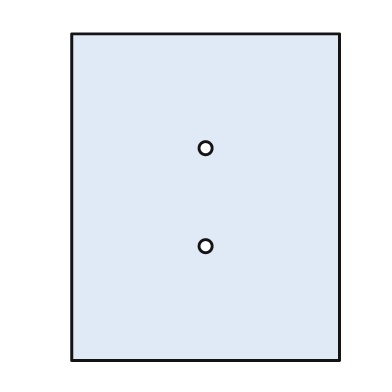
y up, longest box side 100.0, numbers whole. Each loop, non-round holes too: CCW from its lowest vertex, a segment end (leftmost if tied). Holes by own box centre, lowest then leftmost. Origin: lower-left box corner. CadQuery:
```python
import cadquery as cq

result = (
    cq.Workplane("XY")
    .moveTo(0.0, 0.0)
    .lineTo(82.0, 0.0)
    .lineTo(82.0, 100.0)
    .lineTo(0.0, 100.0)
    .close()
    .moveTo(41.0, 35.0)
    .circle(2.0)
    .moveTo(41.0, 65.0)
    .circle(2.0)
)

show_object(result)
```